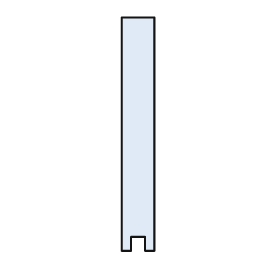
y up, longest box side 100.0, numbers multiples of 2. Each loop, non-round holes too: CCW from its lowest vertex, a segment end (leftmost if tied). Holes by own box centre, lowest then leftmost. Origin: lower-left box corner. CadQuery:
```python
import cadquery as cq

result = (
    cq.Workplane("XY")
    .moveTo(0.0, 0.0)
    .lineTo(4.0, 0.0)
    .lineTo(4.0, 6.0)
    .lineTo(10.0, 6.0)
    .lineTo(10.0, 0.0)
    .lineTo(14.0, 0.0)
    .lineTo(14.0, 100.0)
    .lineTo(0.0, 100.0)
    .close()
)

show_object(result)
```